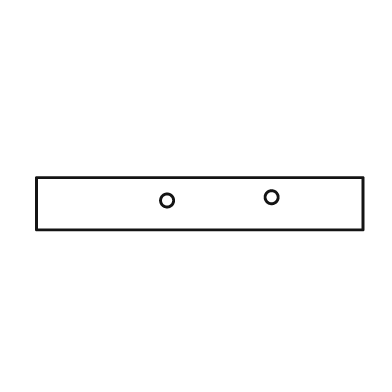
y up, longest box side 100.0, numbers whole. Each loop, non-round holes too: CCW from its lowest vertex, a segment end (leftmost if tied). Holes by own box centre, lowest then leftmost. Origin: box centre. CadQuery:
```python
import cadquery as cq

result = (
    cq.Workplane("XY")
    .moveTo(-50.0, -8.0)
    .lineTo(50.0, -8.0)
    .lineTo(50.0, 8.0)
    .lineTo(-50.0, 8.0)
    .close()
    .moveTo(-10.0, 1.0)
    .circle(2.0)
    .moveTo(22.0, 2.0)
    .circle(2.0)
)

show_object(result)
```